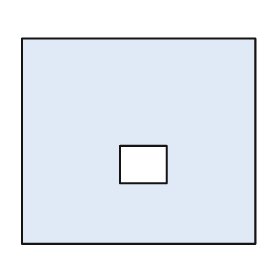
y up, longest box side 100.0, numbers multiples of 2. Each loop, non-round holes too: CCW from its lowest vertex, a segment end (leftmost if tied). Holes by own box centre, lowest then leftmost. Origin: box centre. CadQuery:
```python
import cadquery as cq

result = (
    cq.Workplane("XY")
    .moveTo(-50.0, -44.0)
    .lineTo(50.0, -44.0)
    .lineTo(50.0, 44.0)
    .lineTo(-50.0, 44.0)
    .close()
    .moveTo(-8.0, -18.0)
    .lineTo(12.0, -18.0)
    .lineTo(12.0, -2.0)
    .lineTo(-8.0, -2.0)
    .close()
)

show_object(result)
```